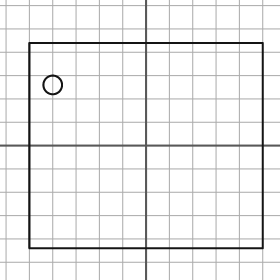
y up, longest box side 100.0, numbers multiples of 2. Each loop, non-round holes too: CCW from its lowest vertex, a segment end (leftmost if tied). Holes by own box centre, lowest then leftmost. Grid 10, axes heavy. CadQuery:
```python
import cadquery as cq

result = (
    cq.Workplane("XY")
    .moveTo(-50.0, -44.0)
    .lineTo(50.0, -44.0)
    .lineTo(50.0, 44.0)
    .lineTo(-50.0, 44.0)
    .close()
    .moveTo(-40.0, 26.0)
    .circle(4.0)
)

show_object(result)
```